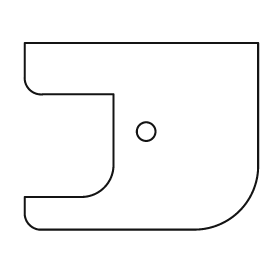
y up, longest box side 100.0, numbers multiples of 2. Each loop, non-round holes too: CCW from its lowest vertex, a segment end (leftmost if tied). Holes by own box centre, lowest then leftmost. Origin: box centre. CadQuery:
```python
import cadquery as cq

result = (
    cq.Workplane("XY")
    .moveTo(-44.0, -40.0)
    .lineTo(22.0, -40.0)
    .threePointArc((42.0, -32.0), (50.0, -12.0))
    .lineTo(50.0, 40.0)
    .lineTo(-50.0, 40.0)
    .lineTo(-50.0, 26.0)
    .threePointArc((-48.0, 20.0), (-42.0, 18.0))
    .lineTo(-12.0, 18.0)
    .lineTo(-12.0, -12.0)
    .threePointArc((-16.0, -22.0), (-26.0, -26.0))
    .lineTo(-50.0, -26.0)
    .lineTo(-50.0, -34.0)
    .threePointArc((-48.0, -38.0), (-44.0, -40.0))
    .close()
    .moveTo(2.0, 2.0)
    .circle(4.0)
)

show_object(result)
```